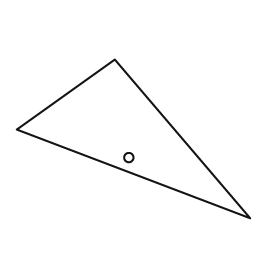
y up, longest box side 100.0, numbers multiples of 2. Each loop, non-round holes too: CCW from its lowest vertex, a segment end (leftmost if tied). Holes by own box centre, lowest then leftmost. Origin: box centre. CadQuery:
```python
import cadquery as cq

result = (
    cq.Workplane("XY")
    .moveTo(50.0, -34.0)
    .lineTo(-8.0, 34.0)
    .lineTo(-50.0, 4.0)
    .close()
    .moveTo(-2.0, -8.0)
    .circle(2.0)
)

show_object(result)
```